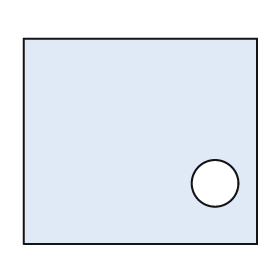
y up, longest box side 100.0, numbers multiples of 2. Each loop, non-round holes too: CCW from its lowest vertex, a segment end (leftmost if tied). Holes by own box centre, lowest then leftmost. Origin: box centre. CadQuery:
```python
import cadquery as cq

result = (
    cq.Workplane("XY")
    .moveTo(-50.0, -44.0)
    .lineTo(50.0, -44.0)
    .lineTo(50.0, 44.0)
    .lineTo(-50.0, 44.0)
    .close()
    .moveTo(32.0, -18.0)
    .circle(10.0)
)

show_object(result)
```